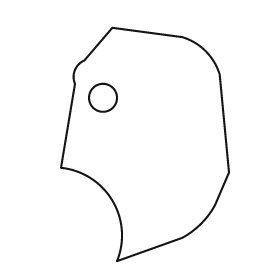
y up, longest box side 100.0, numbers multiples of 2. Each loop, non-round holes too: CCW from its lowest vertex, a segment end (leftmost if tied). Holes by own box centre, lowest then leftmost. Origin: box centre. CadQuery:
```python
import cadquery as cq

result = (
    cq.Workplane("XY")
    .moveTo(-12.0, -50.0)
    .lineTo(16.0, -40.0)
    .threePointArc((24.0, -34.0), (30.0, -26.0))
    .lineTo(36.0, -12.0)
    .lineTo(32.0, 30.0)
    .threePointArc((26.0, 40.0), (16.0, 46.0))
    .lineTo(-14.0, 50.0)
    .lineTo(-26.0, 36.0)
    .threePointArc((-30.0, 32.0), (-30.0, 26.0))
    .lineTo(-36.0, -10.0)
    .threePointArc((-14.0, -24.0), (-12.0, -50.0))
    .close()
    .moveTo(-18.0, 20.0)
    .circle(6.0)
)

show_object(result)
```